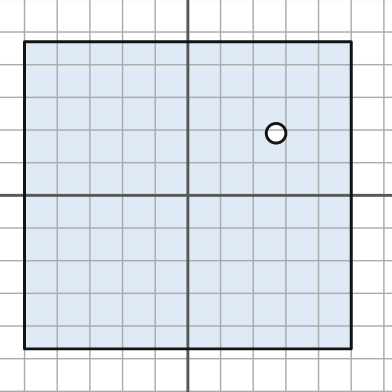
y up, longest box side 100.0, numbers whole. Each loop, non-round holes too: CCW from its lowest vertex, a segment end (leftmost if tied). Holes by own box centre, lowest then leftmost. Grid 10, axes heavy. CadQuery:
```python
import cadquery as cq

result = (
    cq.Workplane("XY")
    .moveTo(-50.0, -47.0)
    .lineTo(50.0, -47.0)
    .lineTo(50.0, 47.0)
    .lineTo(-50.0, 47.0)
    .close()
    .moveTo(27.0, 19.0)
    .circle(3.0)
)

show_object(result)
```